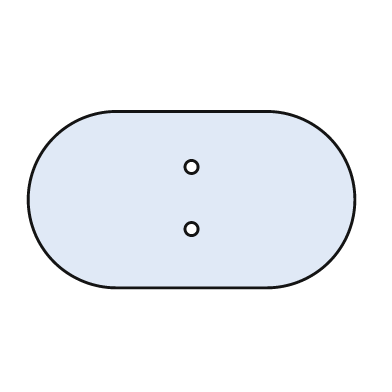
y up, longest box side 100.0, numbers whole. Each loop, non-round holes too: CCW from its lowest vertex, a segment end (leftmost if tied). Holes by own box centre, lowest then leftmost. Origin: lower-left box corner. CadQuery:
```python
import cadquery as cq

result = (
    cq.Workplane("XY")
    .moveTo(27.0, 0.0)
    .lineTo(73.0, 0.0)
    .threePointArc((100.0, 27.0), (73.0, 54.0))
    .lineTo(27.0, 54.0)
    .threePointArc((0.0, 27.0), (27.0, 0.0))
    .close()
    .moveTo(50.0, 18.0)
    .circle(2.0)
    .moveTo(50.0, 37.0)
    .circle(2.0)
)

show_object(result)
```